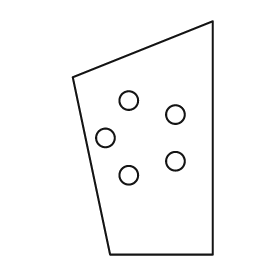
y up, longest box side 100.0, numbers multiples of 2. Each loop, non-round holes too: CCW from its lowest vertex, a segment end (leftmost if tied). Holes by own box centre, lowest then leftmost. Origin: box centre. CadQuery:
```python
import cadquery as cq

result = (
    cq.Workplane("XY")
    .moveTo(-14.0, -50.0)
    .lineTo(30.0, -50.0)
    .lineTo(30.0, 50.0)
    .lineTo(-30.0, 26.0)
    .close()
    .moveTo(-6.0, -16.0)
    .circle(4.0)
    .moveTo(14.0, -10.0)
    .circle(4.0)
    .moveTo(-16.0, 0.0)
    .circle(4.0)
    .moveTo(14.0, 10.0)
    .circle(4.0)
    .moveTo(-6.0, 16.0)
    .circle(4.0)
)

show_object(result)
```